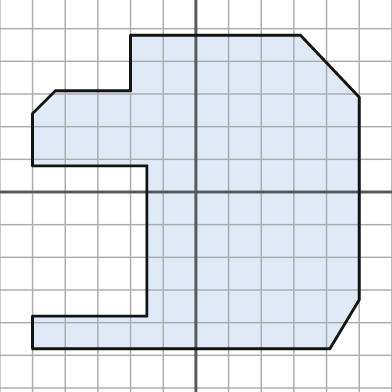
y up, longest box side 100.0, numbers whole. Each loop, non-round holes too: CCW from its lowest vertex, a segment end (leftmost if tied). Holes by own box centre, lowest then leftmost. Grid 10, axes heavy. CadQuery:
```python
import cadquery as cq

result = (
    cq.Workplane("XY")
    .moveTo(-50.0, -48.0)
    .lineTo(41.0, -48.0)
    .lineTo(50.0, -33.0)
    .lineTo(50.0, 29.0)
    .lineTo(32.0, 48.0)
    .lineTo(-20.0, 48.0)
    .lineTo(-20.0, 31.0)
    .lineTo(-43.0, 31.0)
    .lineTo(-50.0, 24.0)
    .lineTo(-50.0, 8.0)
    .lineTo(-15.0, 8.0)
    .lineTo(-15.0, -38.0)
    .lineTo(-50.0, -38.0)
    .close()
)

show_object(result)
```